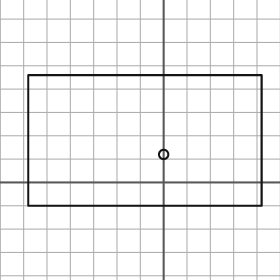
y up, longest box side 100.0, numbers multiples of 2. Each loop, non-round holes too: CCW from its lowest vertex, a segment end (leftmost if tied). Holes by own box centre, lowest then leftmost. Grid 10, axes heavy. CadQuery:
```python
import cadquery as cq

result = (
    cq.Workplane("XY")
    .moveTo(-58.0, -10.0)
    .lineTo(42.0, -10.0)
    .lineTo(42.0, 46.0)
    .lineTo(-58.0, 46.0)
    .close()
    .moveTo(0.0, 12.0)
    .circle(2.0)
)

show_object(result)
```